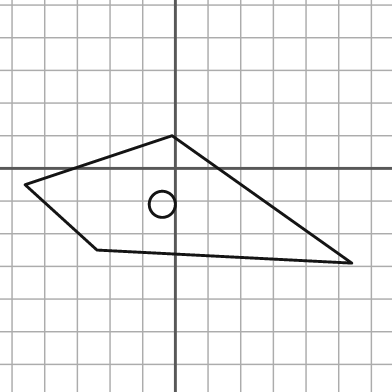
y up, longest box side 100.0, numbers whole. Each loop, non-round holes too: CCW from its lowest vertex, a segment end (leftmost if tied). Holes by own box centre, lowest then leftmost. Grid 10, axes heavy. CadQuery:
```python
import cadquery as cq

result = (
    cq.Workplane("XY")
    .moveTo(54.0, -29.0)
    .lineTo(-1.0, 10.0)
    .lineTo(-46.0, -5.0)
    .lineTo(-24.0, -25.0)
    .close()
    .moveTo(-4.0, -11.0)
    .circle(4.0)
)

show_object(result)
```